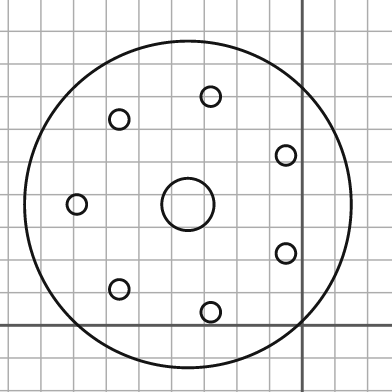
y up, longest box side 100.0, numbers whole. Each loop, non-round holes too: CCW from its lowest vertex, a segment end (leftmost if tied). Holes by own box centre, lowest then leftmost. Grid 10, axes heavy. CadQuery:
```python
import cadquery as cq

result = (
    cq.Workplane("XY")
    .moveTo(-35.0, 37.0)
    .circle(50.0)
    .moveTo(-28.0, 4.0)
    .circle(3.0)
    .moveTo(-56.0, 11.0)
    .circle(3.0)
    .moveTo(-5.0, 22.0)
    .circle(3.0)
    .moveTo(-69.0, 37.0)
    .circle(3.0)
    .moveTo(-35.0, 37.0)
    .circle(8.0)
    .moveTo(-5.0, 52.0)
    .circle(3.0)
    .moveTo(-56.0, 63.0)
    .circle(3.0)
    .moveTo(-28.0, 70.0)
    .circle(3.0)
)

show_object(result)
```